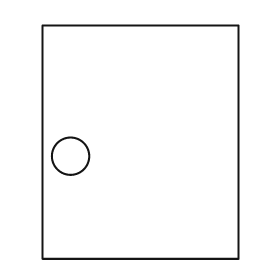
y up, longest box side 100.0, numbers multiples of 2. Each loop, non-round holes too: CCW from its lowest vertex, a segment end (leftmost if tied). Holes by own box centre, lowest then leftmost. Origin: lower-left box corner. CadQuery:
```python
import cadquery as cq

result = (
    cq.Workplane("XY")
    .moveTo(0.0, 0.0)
    .lineTo(84.0, 0.0)
    .lineTo(84.0, 100.0)
    .lineTo(0.0, 100.0)
    .close()
    .moveTo(12.0, 44.0)
    .circle(8.0)
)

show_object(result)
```